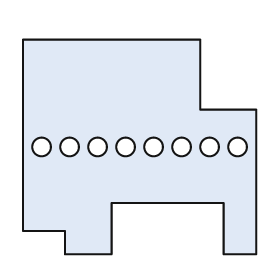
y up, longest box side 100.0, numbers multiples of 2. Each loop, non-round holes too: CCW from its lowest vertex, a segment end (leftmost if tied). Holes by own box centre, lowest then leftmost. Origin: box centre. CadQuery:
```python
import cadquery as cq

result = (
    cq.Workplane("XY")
    .moveTo(-32.0, -46.0)
    .lineTo(-12.0, -46.0)
    .lineTo(-12.0, -24.0)
    .lineTo(36.0, -24.0)
    .lineTo(36.0, -46.0)
    .lineTo(50.0, -46.0)
    .lineTo(50.0, 16.0)
    .lineTo(26.0, 16.0)
    .lineTo(26.0, 46.0)
    .lineTo(-50.0, 46.0)
    .lineTo(-50.0, -36.0)
    .lineTo(-32.0, -36.0)
    .close()
    .moveTo(-42.0, 0.0)
    .circle(4.0)
    .moveTo(-30.0, 0.0)
    .circle(4.0)
    .moveTo(-18.0, 0.0)
    .circle(4.0)
    .moveTo(-6.0, 0.0)
    .circle(4.0)
    .moveTo(6.0, 0.0)
    .circle(4.0)
    .moveTo(18.0, 0.0)
    .circle(4.0)
    .moveTo(30.0, 0.0)
    .circle(4.0)
    .moveTo(42.0, 0.0)
    .circle(4.0)
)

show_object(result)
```